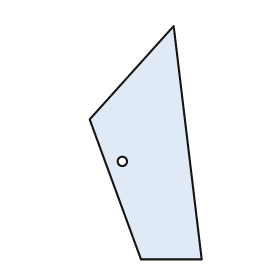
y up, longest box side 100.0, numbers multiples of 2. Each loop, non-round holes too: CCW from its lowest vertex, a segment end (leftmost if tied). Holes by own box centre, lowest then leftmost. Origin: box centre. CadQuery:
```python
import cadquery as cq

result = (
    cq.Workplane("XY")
    .moveTo(-2.0, -50.0)
    .lineTo(24.0, -50.0)
    .lineTo(12.0, 50.0)
    .lineTo(-24.0, 10.0)
    .close()
    .moveTo(-10.0, -8.0)
    .circle(2.0)
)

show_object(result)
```